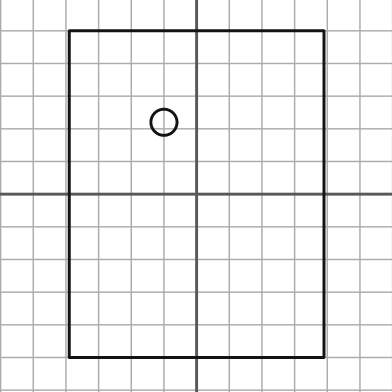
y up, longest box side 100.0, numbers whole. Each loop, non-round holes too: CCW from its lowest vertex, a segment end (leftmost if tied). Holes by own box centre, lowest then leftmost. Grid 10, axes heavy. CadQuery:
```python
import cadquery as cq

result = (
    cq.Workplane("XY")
    .moveTo(-39.0, -50.0)
    .lineTo(39.0, -50.0)
    .lineTo(39.0, 50.0)
    .lineTo(-39.0, 50.0)
    .close()
    .moveTo(-10.0, 22.0)
    .circle(4.0)
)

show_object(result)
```